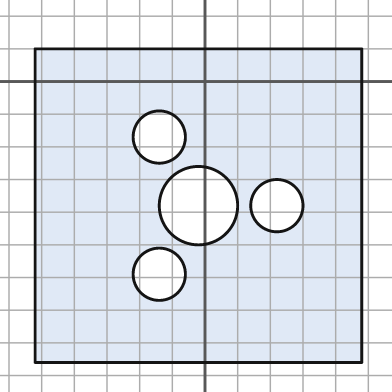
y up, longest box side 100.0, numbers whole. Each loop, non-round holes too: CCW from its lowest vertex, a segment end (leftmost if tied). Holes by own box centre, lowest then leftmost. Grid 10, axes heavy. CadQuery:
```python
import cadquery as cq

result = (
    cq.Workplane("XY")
    .moveTo(-52.0, -86.0)
    .lineTo(48.0, -86.0)
    .lineTo(48.0, 10.0)
    .lineTo(-52.0, 10.0)
    .close()
    .moveTo(-14.0, -59.0)
    .circle(8.0)
    .moveTo(-2.0, -38.0)
    .circle(12.0)
    .moveTo(22.0, -38.0)
    .circle(8.0)
    .moveTo(-14.0, -17.0)
    .circle(8.0)
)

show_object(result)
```